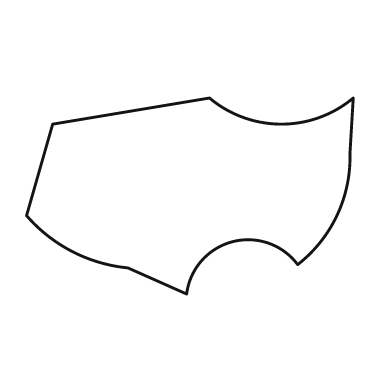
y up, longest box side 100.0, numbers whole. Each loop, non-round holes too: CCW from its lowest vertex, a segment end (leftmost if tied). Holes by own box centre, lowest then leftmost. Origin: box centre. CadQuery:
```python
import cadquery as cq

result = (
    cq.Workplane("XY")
    .moveTo(-1.0, -30.0)
    .threePointArc((13.0, -14.0), (33.0, -21.0))
    .threePointArc((45.0, -6.0), (49.0, 13.0))
    .lineTo(50.0, 30.0)
    .threePointArc((28.0, 22.0), (6.0, 30.0))
    .lineTo(-42.0, 22.0)
    .lineTo(-50.0, -6.0)
    .threePointArc((-36.0, -17.0), (-19.0, -22.0))
    .close()
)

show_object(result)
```